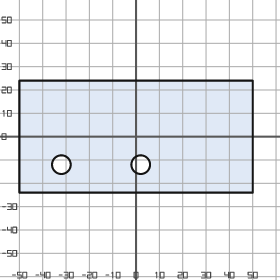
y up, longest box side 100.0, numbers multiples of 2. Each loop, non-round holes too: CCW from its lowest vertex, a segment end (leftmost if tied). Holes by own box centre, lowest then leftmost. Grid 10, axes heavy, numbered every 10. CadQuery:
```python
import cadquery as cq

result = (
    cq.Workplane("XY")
    .moveTo(-50.0, -24.0)
    .lineTo(50.0, -24.0)
    .lineTo(50.0, 24.0)
    .lineTo(-50.0, 24.0)
    .close()
    .moveTo(-32.0, -12.0)
    .circle(4.0)
    .moveTo(2.0, -12.0)
    .circle(4.0)
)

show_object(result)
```